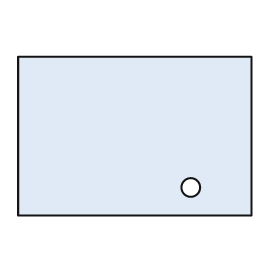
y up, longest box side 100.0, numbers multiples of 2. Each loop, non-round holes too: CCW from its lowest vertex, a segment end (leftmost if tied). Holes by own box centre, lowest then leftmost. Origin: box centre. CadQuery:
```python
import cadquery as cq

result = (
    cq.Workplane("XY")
    .moveTo(-50.0, -34.0)
    .lineTo(50.0, -34.0)
    .lineTo(50.0, 34.0)
    .lineTo(-50.0, 34.0)
    .close()
    .moveTo(24.0, -22.0)
    .circle(4.0)
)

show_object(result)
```